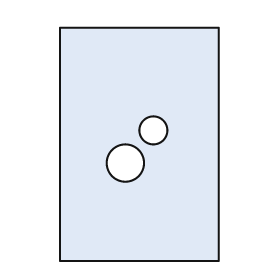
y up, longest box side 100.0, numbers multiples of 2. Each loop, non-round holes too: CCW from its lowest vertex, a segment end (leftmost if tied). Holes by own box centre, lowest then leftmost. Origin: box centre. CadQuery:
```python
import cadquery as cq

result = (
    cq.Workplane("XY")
    .moveTo(-34.0, -50.0)
    .lineTo(34.0, -50.0)
    .lineTo(34.0, 50.0)
    .lineTo(-34.0, 50.0)
    .close()
    .moveTo(-6.0, -8.0)
    .circle(8.0)
    .moveTo(6.0, 6.0)
    .circle(6.0)
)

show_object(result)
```